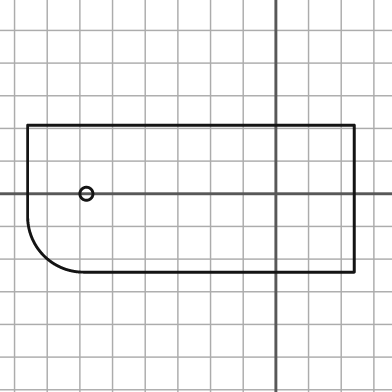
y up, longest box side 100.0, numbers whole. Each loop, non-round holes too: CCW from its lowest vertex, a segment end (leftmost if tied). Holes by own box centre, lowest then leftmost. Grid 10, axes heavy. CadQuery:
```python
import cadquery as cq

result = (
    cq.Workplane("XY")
    .moveTo(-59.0, -24.0)
    .lineTo(24.0, -24.0)
    .lineTo(24.0, 21.0)
    .lineTo(-76.0, 21.0)
    .lineTo(-76.0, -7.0)
    .threePointArc((-71.0, -19.0), (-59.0, -24.0))
    .close()
    .moveTo(-58.0, 0.0)
    .circle(2.0)
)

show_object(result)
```